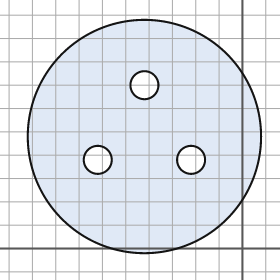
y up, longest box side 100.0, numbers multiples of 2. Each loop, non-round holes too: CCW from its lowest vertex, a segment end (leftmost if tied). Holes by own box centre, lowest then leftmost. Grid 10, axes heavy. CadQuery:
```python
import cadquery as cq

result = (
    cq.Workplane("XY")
    .moveTo(-42.0, 48.0)
    .circle(50.0)
    .moveTo(-62.0, 38.0)
    .circle(6.0)
    .moveTo(-22.0, 38.0)
    .circle(6.0)
    .moveTo(-42.0, 70.0)
    .circle(6.0)
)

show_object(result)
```